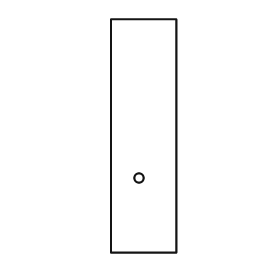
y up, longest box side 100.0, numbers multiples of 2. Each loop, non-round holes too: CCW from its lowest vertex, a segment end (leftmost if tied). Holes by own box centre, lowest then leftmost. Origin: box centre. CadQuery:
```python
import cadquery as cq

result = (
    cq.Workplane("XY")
    .moveTo(-14.0, -50.0)
    .lineTo(14.0, -50.0)
    .lineTo(14.0, 50.0)
    .lineTo(-14.0, 50.0)
    .close()
    .moveTo(-2.0, -18.0)
    .circle(2.0)
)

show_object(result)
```